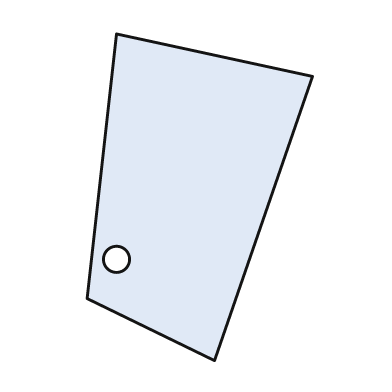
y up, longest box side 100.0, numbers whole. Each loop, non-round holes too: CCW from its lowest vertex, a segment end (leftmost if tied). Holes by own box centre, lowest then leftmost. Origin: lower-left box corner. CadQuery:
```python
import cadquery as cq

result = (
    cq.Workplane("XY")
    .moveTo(39.0, 0.0)
    .lineTo(69.0, 87.0)
    .lineTo(9.0, 100.0)
    .lineTo(0.0, 19.0)
    .close()
    .moveTo(9.0, 31.0)
    .circle(4.0)
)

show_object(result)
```